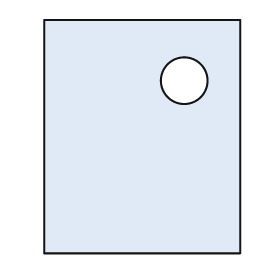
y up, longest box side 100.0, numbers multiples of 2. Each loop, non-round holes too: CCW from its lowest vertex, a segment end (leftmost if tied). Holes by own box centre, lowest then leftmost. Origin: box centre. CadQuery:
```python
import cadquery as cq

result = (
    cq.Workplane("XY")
    .moveTo(-42.0, -50.0)
    .lineTo(42.0, -50.0)
    .lineTo(42.0, 50.0)
    .lineTo(-42.0, 50.0)
    .close()
    .moveTo(18.0, 24.0)
    .circle(10.0)
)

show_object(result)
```